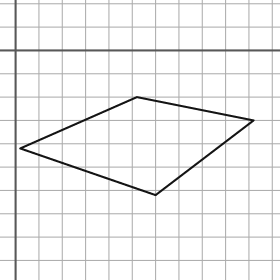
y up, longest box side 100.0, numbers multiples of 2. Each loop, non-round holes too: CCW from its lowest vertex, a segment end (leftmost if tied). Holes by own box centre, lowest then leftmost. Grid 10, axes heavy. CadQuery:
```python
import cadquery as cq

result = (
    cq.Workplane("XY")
    .moveTo(60.0, -62.0)
    .lineTo(102.0, -30.0)
    .lineTo(52.0, -20.0)
    .lineTo(2.0, -42.0)
    .close()
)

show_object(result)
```